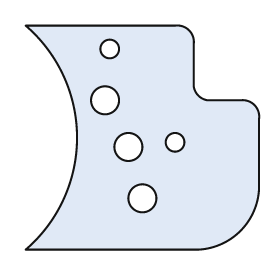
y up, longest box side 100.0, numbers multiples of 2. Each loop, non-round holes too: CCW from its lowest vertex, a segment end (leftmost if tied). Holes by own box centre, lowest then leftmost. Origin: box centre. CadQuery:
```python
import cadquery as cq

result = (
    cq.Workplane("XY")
    .moveTo(-50.0, -48.0)
    .lineTo(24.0, -48.0)
    .threePointArc((42.0, -40.0), (50.0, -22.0))
    .lineTo(50.0, 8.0)
    .threePointArc((48.0, 14.0), (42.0, 16.0))
    .lineTo(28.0, 16.0)
    .threePointArc((24.0, 18.0), (22.0, 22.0))
    .lineTo(22.0, 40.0)
    .threePointArc((20.0, 46.0), (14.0, 48.0))
    .lineTo(-50.0, 48.0)
    .threePointArc((-28.0, 0.0), (-50.0, -48.0))
    .close()
    .moveTo(0.0, -26.0)
    .circle(6.0)
    .moveTo(-6.0, -4.0)
    .circle(6.0)
    .moveTo(14.0, -2.0)
    .circle(4.0)
    .moveTo(-16.0, 16.0)
    .circle(6.0)
    .moveTo(-14.0, 38.0)
    .circle(4.0)
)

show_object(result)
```